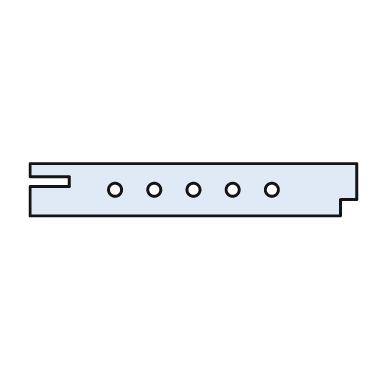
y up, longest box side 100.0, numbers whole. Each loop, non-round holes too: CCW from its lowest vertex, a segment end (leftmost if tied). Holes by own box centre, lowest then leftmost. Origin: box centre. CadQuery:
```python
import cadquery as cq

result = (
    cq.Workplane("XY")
    .moveTo(-50.0, -8.0)
    .lineTo(45.0, -8.0)
    .lineTo(45.0, -3.0)
    .lineTo(50.0, -3.0)
    .lineTo(50.0, 8.0)
    .lineTo(-50.0, 8.0)
    .lineTo(-50.0, 4.0)
    .lineTo(-38.0, 4.0)
    .lineTo(-38.0, 1.0)
    .lineTo(-50.0, 1.0)
    .close()
    .moveTo(-24.0, 0.0)
    .circle(2.0)
    .moveTo(-12.0, 0.0)
    .circle(2.0)
    .moveTo(0.0, 0.0)
    .circle(2.0)
    .moveTo(12.0, 0.0)
    .circle(2.0)
    .moveTo(24.0, 0.0)
    .circle(2.0)
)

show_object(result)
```